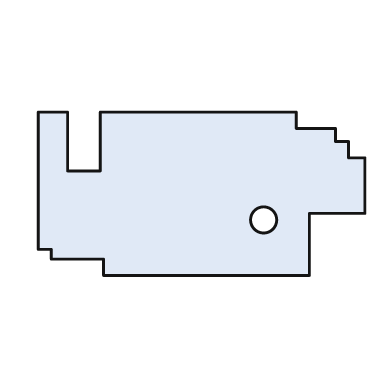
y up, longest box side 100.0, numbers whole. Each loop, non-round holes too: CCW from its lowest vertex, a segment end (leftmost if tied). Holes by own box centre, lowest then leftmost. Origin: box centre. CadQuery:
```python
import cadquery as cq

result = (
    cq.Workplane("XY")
    .moveTo(-30.0, -25.0)
    .lineTo(33.0, -25.0)
    .lineTo(33.0, -6.0)
    .lineTo(50.0, -6.0)
    .lineTo(50.0, 11.0)
    .lineTo(45.0, 11.0)
    .lineTo(45.0, 16.0)
    .lineTo(41.0, 16.0)
    .lineTo(41.0, 20.0)
    .lineTo(29.0, 20.0)
    .lineTo(29.0, 25.0)
    .lineTo(-31.0, 25.0)
    .lineTo(-31.0, 7.0)
    .lineTo(-41.0, 7.0)
    .lineTo(-41.0, 25.0)
    .lineTo(-50.0, 25.0)
    .lineTo(-50.0, -17.0)
    .lineTo(-46.0, -17.0)
    .lineTo(-46.0, -20.0)
    .lineTo(-30.0, -20.0)
    .close()
    .moveTo(19.0, -8.0)
    .circle(4.0)
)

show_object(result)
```